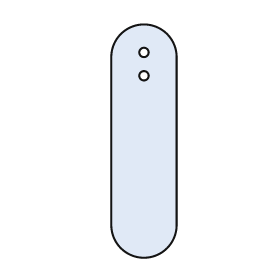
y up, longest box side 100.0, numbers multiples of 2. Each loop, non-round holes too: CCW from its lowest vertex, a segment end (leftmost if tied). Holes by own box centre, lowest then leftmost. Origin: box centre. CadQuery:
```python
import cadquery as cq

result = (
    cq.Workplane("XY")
    .moveTo(-14.0, -36.0)
    .threePointArc((0.0, -50.0), (14.0, -36.0))
    .lineTo(14.0, 36.0)
    .threePointArc((0.0, 50.0), (-14.0, 36.0))
    .close()
    .moveTo(0.0, 28.0)
    .circle(2.0)
    .moveTo(0.0, 38.0)
    .circle(2.0)
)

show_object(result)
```